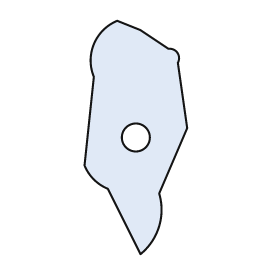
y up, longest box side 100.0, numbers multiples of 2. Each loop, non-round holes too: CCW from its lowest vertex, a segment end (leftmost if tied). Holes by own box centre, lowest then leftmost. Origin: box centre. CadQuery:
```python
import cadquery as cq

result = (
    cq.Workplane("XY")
    .moveTo(2.0, -50.0)
    .threePointArc((10.0, -38.0), (10.0, -24.0))
    .lineTo(22.0, 4.0)
    .lineTo(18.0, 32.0)
    .threePointArc((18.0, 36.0), (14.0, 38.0))
    .lineTo(2.0, 46.0)
    .lineTo(-8.0, 50.0)
    .threePointArc((-18.0, 40.0), (-18.0, 26.0))
    .lineTo(-22.0, -12.0)
    .threePointArc((-18.0, -18.0), (-12.0, -22.0))
    .close()
    .moveTo(0.0, 0.0)
    .circle(6.0)
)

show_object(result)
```